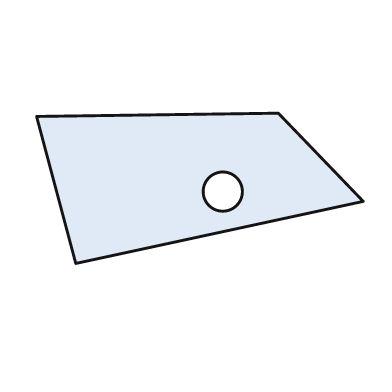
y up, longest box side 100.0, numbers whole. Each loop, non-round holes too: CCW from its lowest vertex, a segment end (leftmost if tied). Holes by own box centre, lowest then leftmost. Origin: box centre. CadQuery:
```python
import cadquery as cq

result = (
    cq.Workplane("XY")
    .moveTo(-38.0, -23.0)
    .lineTo(50.0, -4.0)
    .lineTo(24.0, 23.0)
    .lineTo(-50.0, 22.0)
    .close()
    .moveTo(7.0, -1.0)
    .circle(6.0)
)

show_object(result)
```